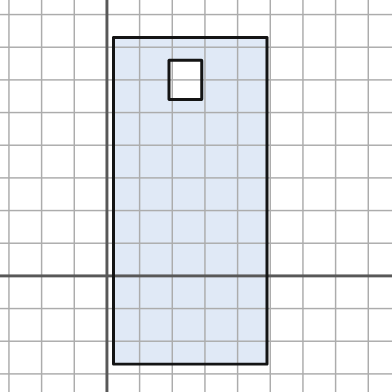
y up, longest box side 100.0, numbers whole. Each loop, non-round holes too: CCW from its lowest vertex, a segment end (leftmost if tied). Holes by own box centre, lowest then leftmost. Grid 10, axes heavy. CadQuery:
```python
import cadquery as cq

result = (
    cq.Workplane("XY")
    .moveTo(2.0, -27.0)
    .lineTo(49.0, -27.0)
    .lineTo(49.0, 73.0)
    .lineTo(2.0, 73.0)
    .close()
    .moveTo(19.0, 54.0)
    .lineTo(29.0, 54.0)
    .lineTo(29.0, 66.0)
    .lineTo(19.0, 66.0)
    .close()
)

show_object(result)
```